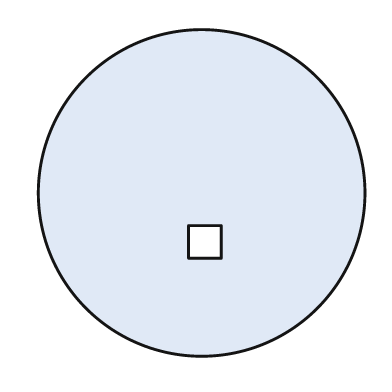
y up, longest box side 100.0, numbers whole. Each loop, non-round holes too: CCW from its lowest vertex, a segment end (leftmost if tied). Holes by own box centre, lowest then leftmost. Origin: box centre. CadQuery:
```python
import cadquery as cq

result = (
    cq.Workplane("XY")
    .moveTo(0.0, 0.0)
    .circle(50.0)
    .moveTo(-4.0, -20.0)
    .lineTo(6.0, -20.0)
    .lineTo(6.0, -10.0)
    .lineTo(-4.0, -10.0)
    .close()
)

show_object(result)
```